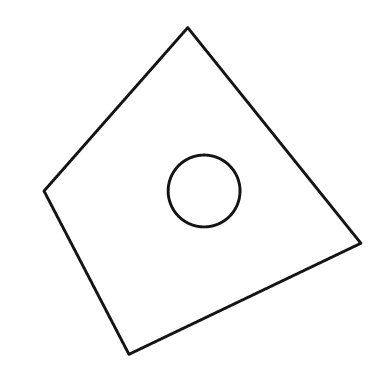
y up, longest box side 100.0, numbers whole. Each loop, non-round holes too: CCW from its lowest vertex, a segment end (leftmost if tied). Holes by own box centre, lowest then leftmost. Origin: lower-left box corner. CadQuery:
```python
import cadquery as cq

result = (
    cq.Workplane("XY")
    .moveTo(26.0, 0.0)
    .lineTo(97.0, 34.0)
    .lineTo(44.0, 100.0)
    .lineTo(0.0, 50.0)
    .close()
    .moveTo(49.0, 50.0)
    .circle(11.0)
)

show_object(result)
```